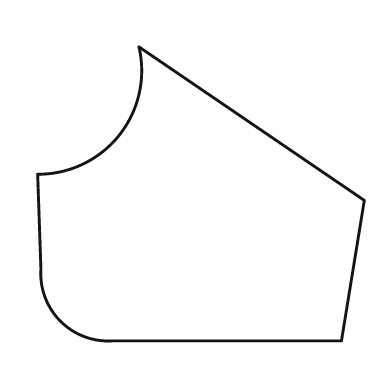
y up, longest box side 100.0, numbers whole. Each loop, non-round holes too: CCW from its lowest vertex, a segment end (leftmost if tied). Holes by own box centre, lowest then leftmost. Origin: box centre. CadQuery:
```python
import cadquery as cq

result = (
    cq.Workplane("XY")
    .moveTo(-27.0, -45.0)
    .lineTo(43.0, -45.0)
    .lineTo(50.0, -2.0)
    .lineTo(-19.0, 45.0)
    .threePointArc((-25.0, 18.0), (-50.0, 6.0))
    .lineTo(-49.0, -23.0)
    .threePointArc((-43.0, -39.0), (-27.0, -45.0))
    .close()
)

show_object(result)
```